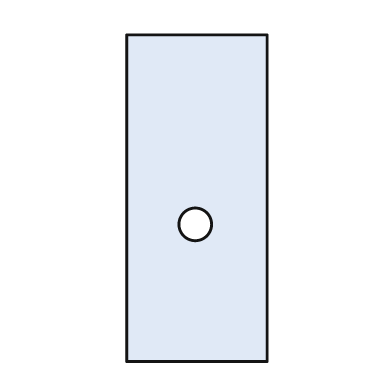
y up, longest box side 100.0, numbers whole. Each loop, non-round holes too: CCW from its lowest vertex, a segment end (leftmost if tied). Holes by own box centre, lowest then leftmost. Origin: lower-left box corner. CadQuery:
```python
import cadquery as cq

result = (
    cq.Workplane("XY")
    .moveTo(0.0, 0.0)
    .lineTo(43.0, 0.0)
    .lineTo(43.0, 100.0)
    .lineTo(0.0, 100.0)
    .close()
    .moveTo(21.0, 42.0)
    .circle(5.0)
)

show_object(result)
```